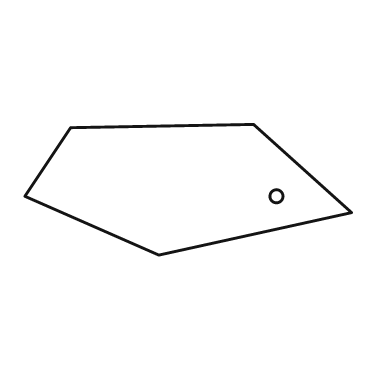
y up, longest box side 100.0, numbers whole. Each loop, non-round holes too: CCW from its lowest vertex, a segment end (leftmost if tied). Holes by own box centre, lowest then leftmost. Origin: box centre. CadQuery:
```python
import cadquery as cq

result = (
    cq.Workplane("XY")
    .moveTo(-9.0, -20.0)
    .lineTo(50.0, -7.0)
    .lineTo(20.0, 20.0)
    .lineTo(-36.0, 19.0)
    .lineTo(-50.0, -2.0)
    .close()
    .moveTo(27.0, -2.0)
    .circle(2.0)
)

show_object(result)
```